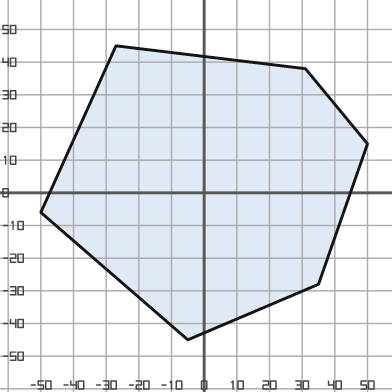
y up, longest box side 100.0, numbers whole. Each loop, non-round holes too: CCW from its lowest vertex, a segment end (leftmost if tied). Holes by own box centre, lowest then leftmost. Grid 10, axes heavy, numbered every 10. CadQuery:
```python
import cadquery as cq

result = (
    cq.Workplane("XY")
    .moveTo(-5.0, -45.0)
    .lineTo(35.0, -28.0)
    .lineTo(50.0, 15.0)
    .lineTo(31.0, 38.0)
    .lineTo(-27.0, 45.0)
    .lineTo(-50.0, -6.0)
    .close()
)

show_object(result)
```